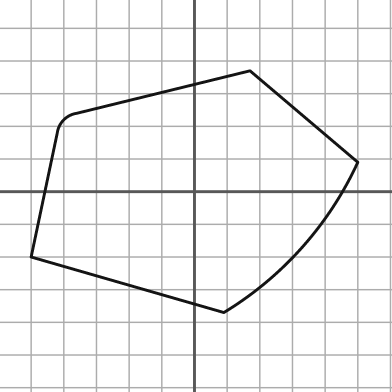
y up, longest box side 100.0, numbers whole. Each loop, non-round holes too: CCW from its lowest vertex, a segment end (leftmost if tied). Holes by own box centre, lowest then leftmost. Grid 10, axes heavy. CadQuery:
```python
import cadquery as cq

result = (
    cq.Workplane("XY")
    .moveTo(9.0, -37.0)
    .threePointArc((33.0, -17.0), (50.0, 9.0))
    .lineTo(17.0, 37.0)
    .lineTo(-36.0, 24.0)
    .threePointArc((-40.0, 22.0), (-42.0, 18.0))
    .lineTo(-50.0, -20.0)
    .close()
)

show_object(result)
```